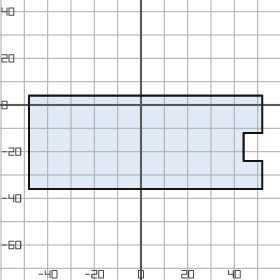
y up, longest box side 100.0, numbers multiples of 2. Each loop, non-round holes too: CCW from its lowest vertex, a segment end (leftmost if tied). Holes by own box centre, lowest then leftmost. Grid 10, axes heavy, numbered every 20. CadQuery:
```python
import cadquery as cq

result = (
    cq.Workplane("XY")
    .moveTo(-48.0, -36.0)
    .lineTo(52.0, -36.0)
    .lineTo(52.0, -24.0)
    .lineTo(44.0, -24.0)
    .lineTo(44.0, -12.0)
    .lineTo(52.0, -12.0)
    .lineTo(52.0, 4.0)
    .lineTo(-48.0, 4.0)
    .close()
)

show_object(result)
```